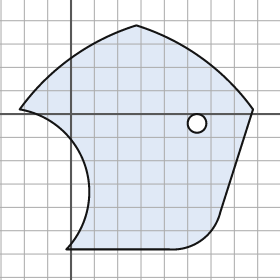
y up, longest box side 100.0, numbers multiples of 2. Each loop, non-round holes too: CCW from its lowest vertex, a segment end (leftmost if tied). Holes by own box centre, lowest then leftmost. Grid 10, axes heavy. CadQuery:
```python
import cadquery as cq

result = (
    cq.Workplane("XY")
    .moveTo(-2.0, -58.0)
    .lineTo(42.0, -58.0)
    .threePointArc((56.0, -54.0), (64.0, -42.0))
    .lineTo(78.0, 2.0)
    .threePointArc((56.0, 24.0), (28.0, 38.0))
    .threePointArc((0.0, 24.0), (-22.0, 2.0))
    .threePointArc((6.0, -22.0), (-2.0, -58.0))
    .close()
    .moveTo(54.0, -4.0)
    .circle(4.0)
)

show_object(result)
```